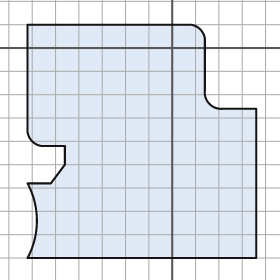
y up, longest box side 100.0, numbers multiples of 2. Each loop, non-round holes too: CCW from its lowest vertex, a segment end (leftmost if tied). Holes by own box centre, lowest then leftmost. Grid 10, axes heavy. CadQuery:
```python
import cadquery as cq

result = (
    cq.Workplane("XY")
    .moveTo(-62.0, -90.0)
    .lineTo(36.0, -90.0)
    .lineTo(36.0, -26.0)
    .lineTo(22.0, -26.0)
    .threePointArc((16.0, -24.0), (14.0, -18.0))
    .lineTo(14.0, 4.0)
    .threePointArc((12.0, 8.0), (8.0, 10.0))
    .lineTo(-62.0, 10.0)
    .lineTo(-62.0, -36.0)
    .threePointArc((-60.0, -40.0), (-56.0, -42.0))
    .lineTo(-46.0, -42.0)
    .lineTo(-46.0, -50.0)
    .lineTo(-52.0, -58.0)
    .lineTo(-62.0, -58.0)
    .threePointArc((-58.0, -74.0), (-62.0, -90.0))
    .close()
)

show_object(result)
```